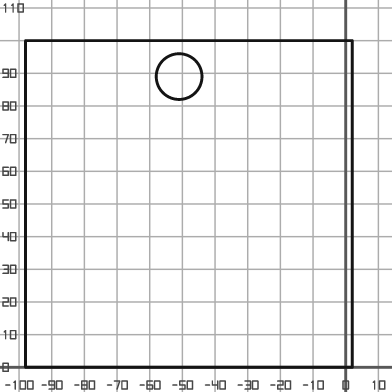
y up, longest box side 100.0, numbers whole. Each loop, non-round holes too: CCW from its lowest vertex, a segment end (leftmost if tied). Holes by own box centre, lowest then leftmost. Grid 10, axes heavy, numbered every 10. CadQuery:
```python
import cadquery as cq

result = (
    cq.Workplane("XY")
    .moveTo(-98.0, 0.0)
    .lineTo(2.0, 0.0)
    .lineTo(2.0, 100.0)
    .lineTo(-98.0, 100.0)
    .close()
    .moveTo(-51.0, 89.0)
    .circle(7.0)
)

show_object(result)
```